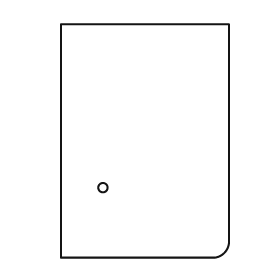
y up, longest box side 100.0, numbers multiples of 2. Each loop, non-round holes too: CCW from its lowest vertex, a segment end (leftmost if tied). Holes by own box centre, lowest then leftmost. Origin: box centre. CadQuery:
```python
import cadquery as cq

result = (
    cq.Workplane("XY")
    .moveTo(-36.0, -50.0)
    .lineTo(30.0, -50.0)
    .threePointArc((34.0, -48.0), (36.0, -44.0))
    .lineTo(36.0, 50.0)
    .lineTo(-36.0, 50.0)
    .close()
    .moveTo(-18.0, -20.0)
    .circle(2.0)
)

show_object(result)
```